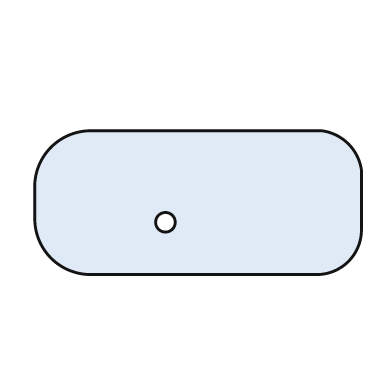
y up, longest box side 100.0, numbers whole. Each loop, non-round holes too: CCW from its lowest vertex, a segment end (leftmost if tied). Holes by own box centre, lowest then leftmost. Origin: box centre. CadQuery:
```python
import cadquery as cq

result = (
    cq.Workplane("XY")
    .moveTo(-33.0, -22.0)
    .lineTo(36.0, -22.0)
    .threePointArc((46.0, -18.0), (50.0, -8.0))
    .lineTo(50.0, 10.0)
    .threePointArc((46.0, 18.0), (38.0, 22.0))
    .lineTo(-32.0, 22.0)
    .threePointArc((-45.0, 17.0), (-50.0, 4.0))
    .lineTo(-50.0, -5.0)
    .threePointArc((-45.0, -17.0), (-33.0, -22.0))
    .close()
    .moveTo(-10.0, -6.0)
    .circle(3.0)
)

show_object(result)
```